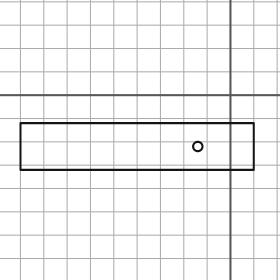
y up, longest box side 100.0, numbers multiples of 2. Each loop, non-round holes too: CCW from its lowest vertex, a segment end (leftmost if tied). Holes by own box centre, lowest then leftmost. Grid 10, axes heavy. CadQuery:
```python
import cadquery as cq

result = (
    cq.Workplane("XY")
    .moveTo(-90.0, -32.0)
    .lineTo(10.0, -32.0)
    .lineTo(10.0, -12.0)
    .lineTo(-90.0, -12.0)
    .close()
    .moveTo(-14.0, -22.0)
    .circle(2.0)
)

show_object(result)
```